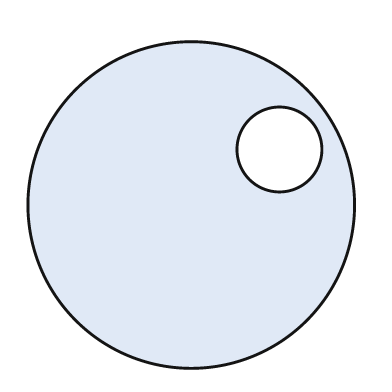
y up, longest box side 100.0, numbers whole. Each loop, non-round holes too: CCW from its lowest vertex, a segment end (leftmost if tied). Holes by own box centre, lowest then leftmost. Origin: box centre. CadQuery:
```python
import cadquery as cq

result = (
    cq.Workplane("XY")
    .moveTo(0.0, 0.0)
    .circle(50.0)
    .moveTo(27.0, 17.0)
    .circle(13.0)
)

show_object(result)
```